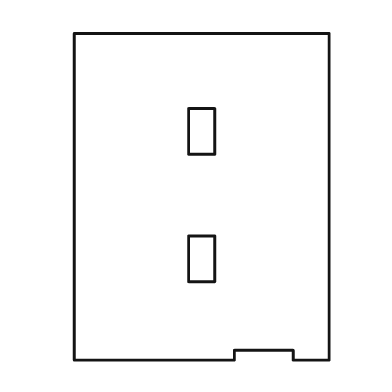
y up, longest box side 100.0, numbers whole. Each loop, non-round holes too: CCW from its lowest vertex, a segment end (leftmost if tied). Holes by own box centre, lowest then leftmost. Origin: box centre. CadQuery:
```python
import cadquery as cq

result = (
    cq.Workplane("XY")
    .moveTo(-39.0, -50.0)
    .lineTo(10.0, -50.0)
    .lineTo(10.0, -47.0)
    .lineTo(28.0, -47.0)
    .lineTo(28.0, -50.0)
    .lineTo(39.0, -50.0)
    .lineTo(39.0, 50.0)
    .lineTo(-39.0, 50.0)
    .close()
    .moveTo(-4.0, -26.0)
    .lineTo(4.0, -26.0)
    .lineTo(4.0, -12.0)
    .lineTo(-4.0, -12.0)
    .close()
    .moveTo(-4.0, 13.0)
    .lineTo(4.0, 13.0)
    .lineTo(4.0, 27.0)
    .lineTo(-4.0, 27.0)
    .close()
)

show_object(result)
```